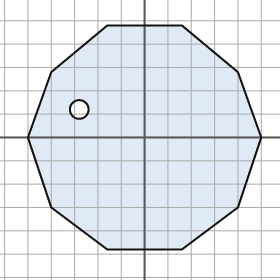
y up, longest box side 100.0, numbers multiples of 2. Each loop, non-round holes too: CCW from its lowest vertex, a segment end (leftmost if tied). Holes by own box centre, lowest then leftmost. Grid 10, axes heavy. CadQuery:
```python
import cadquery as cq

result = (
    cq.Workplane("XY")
    .moveTo(-16.0, -48.0)
    .lineTo(16.0, -48.0)
    .lineTo(40.0, -30.0)
    .lineTo(50.0, 0.0)
    .lineTo(40.0, 28.0)
    .lineTo(16.0, 48.0)
    .lineTo(-16.0, 48.0)
    .lineTo(-40.0, 28.0)
    .lineTo(-50.0, 0.0)
    .lineTo(-40.0, -30.0)
    .close()
    .moveTo(-28.0, 12.0)
    .circle(4.0)
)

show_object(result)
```